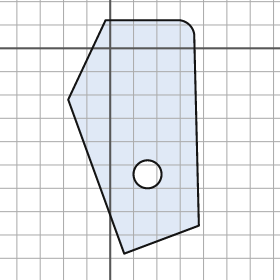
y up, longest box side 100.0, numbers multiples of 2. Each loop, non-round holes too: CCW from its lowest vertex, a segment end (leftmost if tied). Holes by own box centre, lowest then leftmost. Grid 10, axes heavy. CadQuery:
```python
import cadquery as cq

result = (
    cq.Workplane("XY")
    .moveTo(6.0, -88.0)
    .lineTo(38.0, -76.0)
    .lineTo(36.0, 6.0)
    .threePointArc((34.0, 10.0), (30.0, 12.0))
    .lineTo(-2.0, 12.0)
    .lineTo(-18.0, -22.0)
    .close()
    .moveTo(16.0, -54.0)
    .circle(6.0)
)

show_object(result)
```